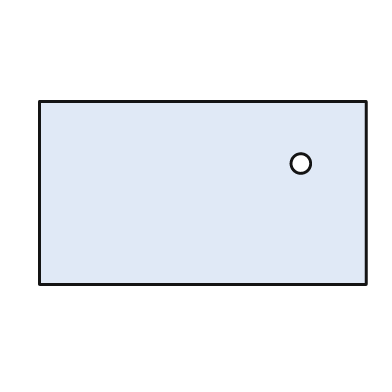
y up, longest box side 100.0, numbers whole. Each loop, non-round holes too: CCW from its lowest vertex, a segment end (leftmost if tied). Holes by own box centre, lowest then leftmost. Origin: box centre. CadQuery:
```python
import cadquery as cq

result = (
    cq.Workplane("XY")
    .moveTo(-50.0, -28.0)
    .lineTo(50.0, -28.0)
    .lineTo(50.0, 28.0)
    .lineTo(-50.0, 28.0)
    .close()
    .moveTo(30.0, 9.0)
    .circle(3.0)
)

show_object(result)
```